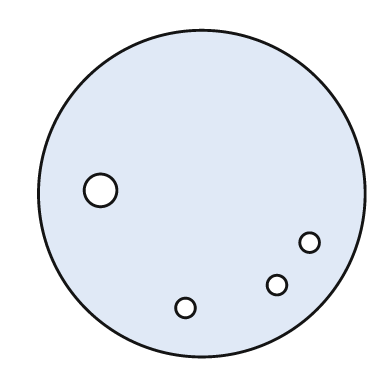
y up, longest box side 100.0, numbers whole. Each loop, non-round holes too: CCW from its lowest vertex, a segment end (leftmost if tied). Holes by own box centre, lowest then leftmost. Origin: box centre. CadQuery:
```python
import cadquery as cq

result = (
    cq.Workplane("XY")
    .moveTo(0.0, 0.0)
    .circle(50.0)
    .moveTo(-5.0, -35.0)
    .circle(3.0)
    .moveTo(23.0, -28.0)
    .circle(3.0)
    .moveTo(33.0, -15.0)
    .circle(3.0)
    .moveTo(-31.0, 1.0)
    .circle(5.0)
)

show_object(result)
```